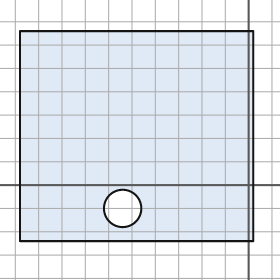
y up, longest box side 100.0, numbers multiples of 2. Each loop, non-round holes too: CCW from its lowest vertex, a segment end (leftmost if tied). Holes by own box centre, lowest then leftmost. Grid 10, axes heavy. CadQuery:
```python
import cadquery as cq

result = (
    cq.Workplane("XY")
    .moveTo(-98.0, -24.0)
    .lineTo(2.0, -24.0)
    .lineTo(2.0, 66.0)
    .lineTo(-98.0, 66.0)
    .close()
    .moveTo(-54.0, -10.0)
    .circle(8.0)
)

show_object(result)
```